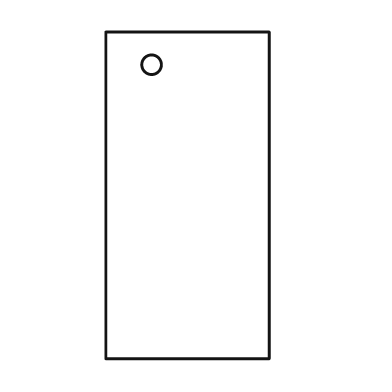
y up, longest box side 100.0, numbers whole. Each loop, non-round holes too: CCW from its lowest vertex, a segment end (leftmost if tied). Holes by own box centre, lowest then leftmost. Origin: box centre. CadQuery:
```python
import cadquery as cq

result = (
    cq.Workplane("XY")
    .moveTo(-25.0, -50.0)
    .lineTo(25.0, -50.0)
    .lineTo(25.0, 50.0)
    .lineTo(-25.0, 50.0)
    .close()
    .moveTo(-11.0, 40.0)
    .circle(3.0)
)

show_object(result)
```